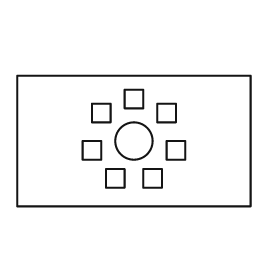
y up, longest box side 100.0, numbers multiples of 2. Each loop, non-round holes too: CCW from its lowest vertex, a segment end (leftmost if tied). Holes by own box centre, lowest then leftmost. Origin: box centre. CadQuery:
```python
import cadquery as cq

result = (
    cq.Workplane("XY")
    .moveTo(-50.0, -28.0)
    .lineTo(50.0, -28.0)
    .lineTo(50.0, 28.0)
    .lineTo(-50.0, 28.0)
    .close()
    .moveTo(-12.0, -20.0)
    .lineTo(-4.0, -20.0)
    .lineTo(-4.0, -12.0)
    .lineTo(-12.0, -12.0)
    .close()
    .moveTo(4.0, -20.0)
    .lineTo(12.0, -20.0)
    .lineTo(12.0, -12.0)
    .lineTo(4.0, -12.0)
    .close()
    .moveTo(-22.0, -8.0)
    .lineTo(-14.0, -8.0)
    .lineTo(-14.0, 0.0)
    .lineTo(-22.0, 0.0)
    .close()
    .moveTo(14.0, -8.0)
    .lineTo(22.0, -8.0)
    .lineTo(22.0, 0.0)
    .lineTo(14.0, 0.0)
    .close()
    .moveTo(0.0, 0.0)
    .circle(8.0)
    .moveTo(-18.0, 8.0)
    .lineTo(-10.0, 8.0)
    .lineTo(-10.0, 16.0)
    .lineTo(-18.0, 16.0)
    .close()
    .moveTo(10.0, 8.0)
    .lineTo(18.0, 8.0)
    .lineTo(18.0, 16.0)
    .lineTo(10.0, 16.0)
    .close()
    .moveTo(-4.0, 14.0)
    .lineTo(4.0, 14.0)
    .lineTo(4.0, 22.0)
    .lineTo(-4.0, 22.0)
    .close()
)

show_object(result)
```